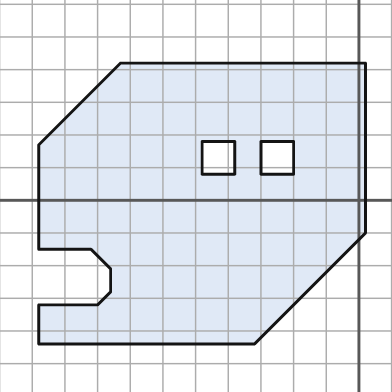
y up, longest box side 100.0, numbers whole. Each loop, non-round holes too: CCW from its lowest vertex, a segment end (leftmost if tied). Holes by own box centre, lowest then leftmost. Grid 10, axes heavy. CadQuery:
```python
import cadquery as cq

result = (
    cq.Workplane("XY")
    .moveTo(-98.0, -44.0)
    .lineTo(-32.0, -44.0)
    .lineTo(2.0, -10.0)
    .lineTo(2.0, 42.0)
    .lineTo(-73.0, 42.0)
    .lineTo(-98.0, 17.0)
    .lineTo(-98.0, -15.0)
    .lineTo(-82.0, -15.0)
    .lineTo(-76.0, -21.0)
    .lineTo(-76.0, -28.0)
    .lineTo(-80.0, -32.0)
    .lineTo(-98.0, -32.0)
    .close()
    .moveTo(-48.0, 8.0)
    .lineTo(-38.0, 8.0)
    .lineTo(-38.0, 18.0)
    .lineTo(-48.0, 18.0)
    .close()
    .moveTo(-30.0, 8.0)
    .lineTo(-20.0, 8.0)
    .lineTo(-20.0, 18.0)
    .lineTo(-30.0, 18.0)
    .close()
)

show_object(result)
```